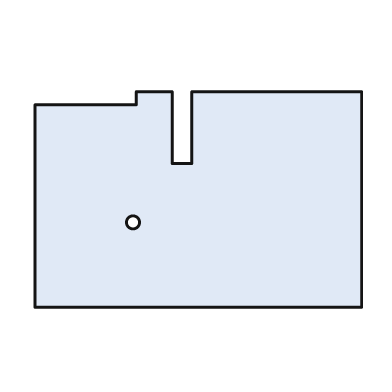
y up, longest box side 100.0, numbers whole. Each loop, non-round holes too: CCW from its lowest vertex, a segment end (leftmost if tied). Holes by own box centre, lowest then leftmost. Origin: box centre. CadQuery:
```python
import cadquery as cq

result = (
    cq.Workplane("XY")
    .moveTo(-50.0, -33.0)
    .lineTo(50.0, -33.0)
    .lineTo(50.0, 33.0)
    .lineTo(-2.0, 33.0)
    .lineTo(-2.0, 11.0)
    .lineTo(-8.0, 11.0)
    .lineTo(-8.0, 33.0)
    .lineTo(-19.0, 33.0)
    .lineTo(-19.0, 29.0)
    .lineTo(-50.0, 29.0)
    .close()
    .moveTo(-20.0, -7.0)
    .circle(2.0)
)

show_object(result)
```